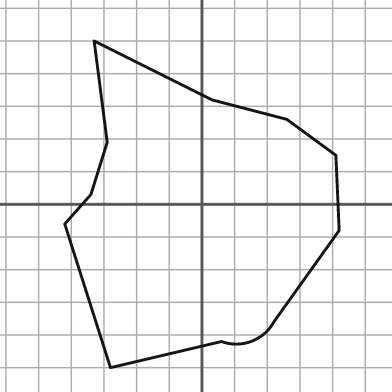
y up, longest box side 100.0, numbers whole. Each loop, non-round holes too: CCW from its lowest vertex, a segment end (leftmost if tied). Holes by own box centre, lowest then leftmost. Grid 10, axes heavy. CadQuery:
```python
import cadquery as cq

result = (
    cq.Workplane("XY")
    .moveTo(-28.0, -50.0)
    .lineTo(6.0, -42.0)
    .threePointArc((15.0, -42.0), (22.0, -36.0))
    .lineTo(42.0, -8.0)
    .lineTo(41.0, 15.0)
    .lineTo(26.0, 26.0)
    .lineTo(3.0, 32.0)
    .lineTo(-33.0, 50.0)
    .lineTo(-29.0, 19.0)
    .lineTo(-34.0, 3.0)
    .lineTo(-42.0, -6.0)
    .close()
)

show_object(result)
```